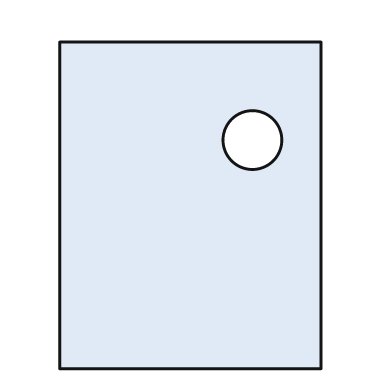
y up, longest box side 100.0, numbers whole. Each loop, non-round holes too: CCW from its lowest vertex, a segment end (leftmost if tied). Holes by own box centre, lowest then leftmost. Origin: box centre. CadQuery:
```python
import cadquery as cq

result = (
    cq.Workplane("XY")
    .moveTo(-40.0, -50.0)
    .lineTo(40.0, -50.0)
    .lineTo(40.0, 50.0)
    .lineTo(-40.0, 50.0)
    .close()
    .moveTo(19.0, 20.0)
    .circle(9.0)
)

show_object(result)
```